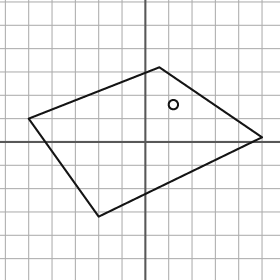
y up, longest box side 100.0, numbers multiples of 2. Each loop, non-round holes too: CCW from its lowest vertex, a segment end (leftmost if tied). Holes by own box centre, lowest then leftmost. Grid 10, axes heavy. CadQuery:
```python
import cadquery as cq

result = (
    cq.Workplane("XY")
    .moveTo(-20.0, -32.0)
    .lineTo(50.0, 2.0)
    .lineTo(6.0, 32.0)
    .lineTo(-50.0, 10.0)
    .close()
    .moveTo(12.0, 16.0)
    .circle(2.0)
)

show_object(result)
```